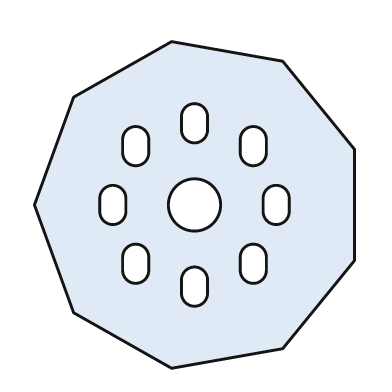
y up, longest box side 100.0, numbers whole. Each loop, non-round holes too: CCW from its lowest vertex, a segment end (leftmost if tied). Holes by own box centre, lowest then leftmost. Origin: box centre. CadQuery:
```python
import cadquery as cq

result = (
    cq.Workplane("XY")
    .moveTo(-7.0, -50.0)
    .lineTo(27.0, -44.0)
    .lineTo(49.0, -17.0)
    .lineTo(49.0, 17.0)
    .lineTo(27.0, 44.0)
    .lineTo(-7.0, 50.0)
    .lineTo(-37.0, 33.0)
    .lineTo(-49.0, 0.0)
    .lineTo(-37.0, -33.0)
    .close()
    .moveTo(-4.0, -27.0)
    .threePointArc((0.0, -31.0), (4.0, -27.0))
    .lineTo(4.0, -23.0)
    .threePointArc((0.0, -19.0), (-4.0, -23.0))
    .close()
    .moveTo(-22.0, -20.0)
    .threePointArc((-18.0, -24.0), (-14.0, -20.0))
    .lineTo(-14.0, -16.0)
    .threePointArc((-18.0, -12.0), (-22.0, -16.0))
    .close()
    .moveTo(14.0, -20.0)
    .threePointArc((18.0, -24.0), (22.0, -20.0))
    .lineTo(22.0, -16.0)
    .threePointArc((18.0, -12.0), (14.0, -16.0))
    .close()
    .moveTo(-29.0, -2.0)
    .threePointArc((-25.0, -6.0), (-21.0, -2.0))
    .lineTo(-21.0, 2.0)
    .threePointArc((-25.0, 6.0), (-29.0, 2.0))
    .close()
    .moveTo(0.0, 0.0)
    .circle(8.0)
    .moveTo(21.0, -2.0)
    .threePointArc((25.0, -6.0), (29.0, -2.0))
    .lineTo(29.0, 2.0)
    .threePointArc((25.0, 6.0), (21.0, 2.0))
    .close()
    .moveTo(-22.0, 16.0)
    .threePointArc((-18.0, 12.0), (-14.0, 16.0))
    .lineTo(-14.0, 20.0)
    .threePointArc((-18.0, 24.0), (-22.0, 20.0))
    .close()
    .moveTo(14.0, 16.0)
    .threePointArc((18.0, 12.0), (22.0, 16.0))
    .lineTo(22.0, 20.0)
    .threePointArc((18.0, 24.0), (14.0, 20.0))
    .close()
    .moveTo(-4.0, 23.0)
    .threePointArc((0.0, 19.0), (4.0, 23.0))
    .lineTo(4.0, 27.0)
    .threePointArc((0.0, 31.0), (-4.0, 27.0))
    .close()
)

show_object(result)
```